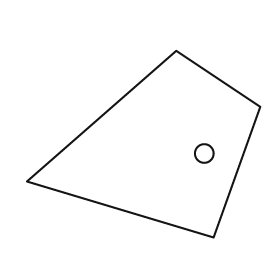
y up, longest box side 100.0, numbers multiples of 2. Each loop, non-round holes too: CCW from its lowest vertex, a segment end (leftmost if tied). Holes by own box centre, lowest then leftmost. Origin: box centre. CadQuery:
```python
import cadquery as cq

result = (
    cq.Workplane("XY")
    .moveTo(30.0, -40.0)
    .lineTo(50.0, 16.0)
    .lineTo(14.0, 40.0)
    .lineTo(-50.0, -16.0)
    .close()
    .moveTo(26.0, -4.0)
    .circle(4.0)
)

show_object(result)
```